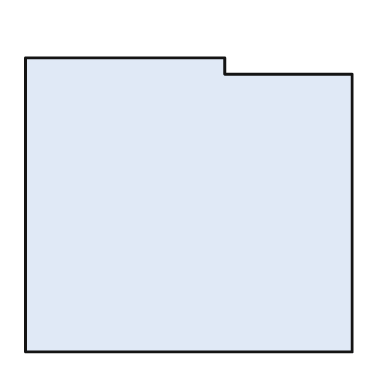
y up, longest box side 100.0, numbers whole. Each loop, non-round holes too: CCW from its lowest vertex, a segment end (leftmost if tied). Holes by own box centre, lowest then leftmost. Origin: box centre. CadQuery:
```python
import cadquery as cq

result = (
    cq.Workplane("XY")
    .moveTo(-50.0, -45.0)
    .lineTo(50.0, -45.0)
    .lineTo(50.0, 40.0)
    .lineTo(11.0, 40.0)
    .lineTo(11.0, 45.0)
    .lineTo(-50.0, 45.0)
    .close()
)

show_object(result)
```